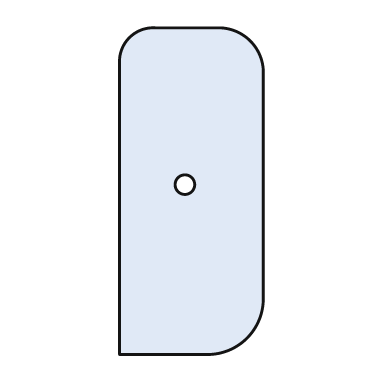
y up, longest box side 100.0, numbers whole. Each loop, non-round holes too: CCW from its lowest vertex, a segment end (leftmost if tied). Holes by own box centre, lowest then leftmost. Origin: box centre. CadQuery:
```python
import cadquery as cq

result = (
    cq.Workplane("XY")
    .moveTo(-22.0, -50.0)
    .lineTo(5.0, -50.0)
    .threePointArc((17.0, -45.0), (22.0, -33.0))
    .lineTo(22.0, 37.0)
    .threePointArc((18.0, 46.0), (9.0, 50.0))
    .lineTo(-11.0, 50.0)
    .threePointArc((-19.0, 47.0), (-22.0, 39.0))
    .close()
    .moveTo(-2.0, 2.0)
    .circle(3.0)
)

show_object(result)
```